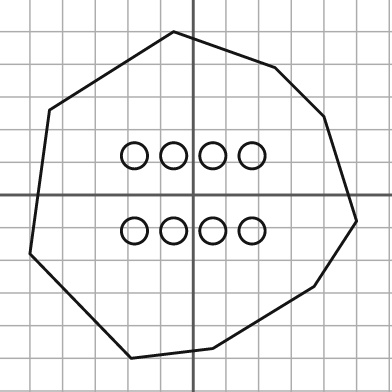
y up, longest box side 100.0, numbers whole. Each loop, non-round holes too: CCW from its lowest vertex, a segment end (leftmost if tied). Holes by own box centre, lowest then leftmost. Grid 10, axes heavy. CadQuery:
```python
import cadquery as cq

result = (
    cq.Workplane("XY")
    .moveTo(-19.0, -50.0)
    .lineTo(6.0, -47.0)
    .lineTo(37.0, -28.0)
    .lineTo(50.0, -8.0)
    .lineTo(40.0, 24.0)
    .lineTo(25.0, 39.0)
    .lineTo(-6.0, 50.0)
    .lineTo(-44.0, 26.0)
    .lineTo(-50.0, -18.0)
    .close()
    .moveTo(-18.0, -11.0)
    .circle(4.0)
    .moveTo(-6.0, -11.0)
    .circle(4.0)
    .moveTo(6.0, -11.0)
    .circle(4.0)
    .moveTo(18.0, -11.0)
    .circle(4.0)
    .moveTo(-18.0, 12.0)
    .circle(4.0)
    .moveTo(-6.0, 12.0)
    .circle(4.0)
    .moveTo(6.0, 12.0)
    .circle(4.0)
    .moveTo(18.0, 12.0)
    .circle(4.0)
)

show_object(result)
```